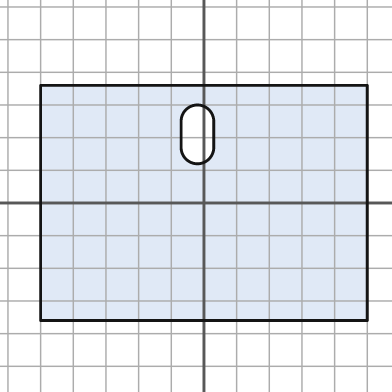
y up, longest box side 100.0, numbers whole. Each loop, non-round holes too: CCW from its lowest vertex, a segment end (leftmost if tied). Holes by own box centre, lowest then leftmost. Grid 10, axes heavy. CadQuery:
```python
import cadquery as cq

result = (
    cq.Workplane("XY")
    .moveTo(-50.0, -36.0)
    .lineTo(50.0, -36.0)
    .lineTo(50.0, 36.0)
    .lineTo(-50.0, 36.0)
    .close()
    .moveTo(-7.0, 17.0)
    .threePointArc((-2.0, 12.0), (3.0, 17.0))
    .lineTo(3.0, 25.0)
    .threePointArc((-2.0, 30.0), (-7.0, 25.0))
    .close()
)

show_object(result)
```